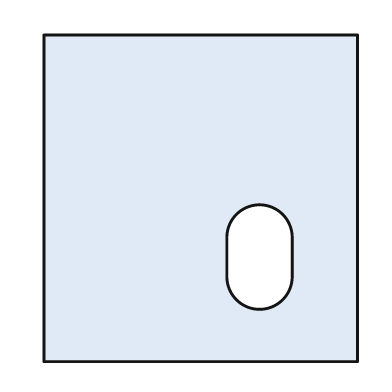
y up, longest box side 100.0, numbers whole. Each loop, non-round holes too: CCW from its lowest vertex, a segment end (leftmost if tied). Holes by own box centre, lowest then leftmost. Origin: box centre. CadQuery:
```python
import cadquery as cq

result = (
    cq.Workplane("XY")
    .moveTo(-48.0, -50.0)
    .lineTo(48.0, -50.0)
    .lineTo(48.0, 50.0)
    .lineTo(-48.0, 50.0)
    .close()
    .moveTo(8.0, -24.0)
    .threePointArc((18.0, -34.0), (28.0, -24.0))
    .lineTo(28.0, -12.0)
    .threePointArc((18.0, -2.0), (8.0, -12.0))
    .close()
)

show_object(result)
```